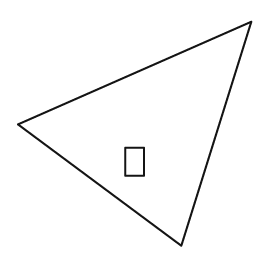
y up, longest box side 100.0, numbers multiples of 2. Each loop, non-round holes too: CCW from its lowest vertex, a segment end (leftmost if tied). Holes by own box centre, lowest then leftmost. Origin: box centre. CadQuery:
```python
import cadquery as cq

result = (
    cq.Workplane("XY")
    .moveTo(20.0, -48.0)
    .lineTo(50.0, 48.0)
    .lineTo(-50.0, 4.0)
    .close()
    .moveTo(-4.0, -18.0)
    .lineTo(4.0, -18.0)
    .lineTo(4.0, -6.0)
    .lineTo(-4.0, -6.0)
    .close()
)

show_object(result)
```